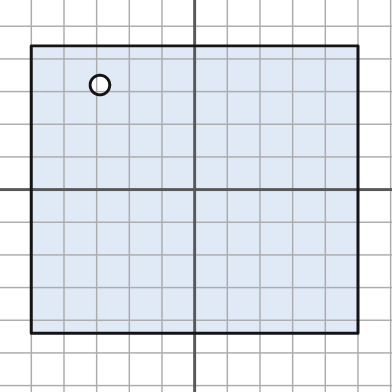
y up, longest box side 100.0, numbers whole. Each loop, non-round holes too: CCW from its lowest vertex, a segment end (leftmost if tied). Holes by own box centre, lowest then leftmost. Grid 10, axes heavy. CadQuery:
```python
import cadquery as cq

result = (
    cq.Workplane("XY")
    .moveTo(-50.0, -44.0)
    .lineTo(50.0, -44.0)
    .lineTo(50.0, 44.0)
    .lineTo(-50.0, 44.0)
    .close()
    .moveTo(-29.0, 32.0)
    .circle(3.0)
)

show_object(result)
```